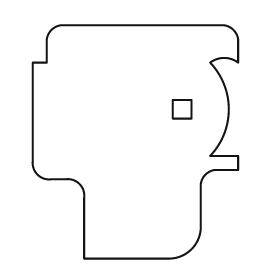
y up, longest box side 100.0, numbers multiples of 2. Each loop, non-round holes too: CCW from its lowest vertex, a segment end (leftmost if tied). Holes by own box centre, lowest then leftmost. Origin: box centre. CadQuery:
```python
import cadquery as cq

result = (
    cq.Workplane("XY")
    .moveTo(-22.0, -50.0)
    .lineTo(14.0, -50.0)
    .threePointArc((24.0, -46.0), (28.0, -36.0))
    .lineTo(28.0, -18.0)
    .threePointArc((30.0, -14.0), (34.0, -12.0))
    .lineTo(44.0, -12.0)
    .lineTo(44.0, -6.0)
    .lineTo(32.0, -6.0)
    .threePointArc((40.0, 14.0), (32.0, 34.0))
    .threePointArc((38.0, 36.0), (44.0, 34.0))
    .lineTo(44.0, 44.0)
    .threePointArc((42.0, 48.0), (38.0, 50.0))
    .lineTo(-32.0, 50.0)
    .threePointArc((-36.0, 48.0), (-38.0, 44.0))
    .lineTo(-38.0, 34.0)
    .lineTo(-44.0, 34.0)
    .lineTo(-44.0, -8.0)
    .threePointArc((-42.0, -14.0), (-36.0, -16.0))
    .lineTo(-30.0, -16.0)
    .threePointArc((-24.0, -18.0), (-22.0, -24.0))
    .close()
    .moveTo(16.0, 10.0)
    .lineTo(24.0, 10.0)
    .lineTo(24.0, 18.0)
    .lineTo(16.0, 18.0)
    .close()
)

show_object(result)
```